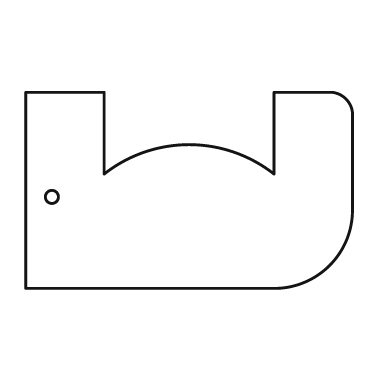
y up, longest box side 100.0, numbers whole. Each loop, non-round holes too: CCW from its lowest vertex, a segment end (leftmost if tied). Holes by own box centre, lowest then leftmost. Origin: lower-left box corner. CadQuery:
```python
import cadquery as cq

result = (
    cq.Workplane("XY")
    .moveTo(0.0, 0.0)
    .lineTo(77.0, 0.0)
    .threePointArc((93.0, 7.0), (100.0, 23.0))
    .lineTo(100.0, 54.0)
    .threePointArc((98.0, 58.0), (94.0, 60.0))
    .lineTo(76.0, 60.0)
    .lineTo(76.0, 35.0)
    .threePointArc((50.0, 44.0), (24.0, 35.0))
    .lineTo(24.0, 60.0)
    .lineTo(0.0, 60.0)
    .close()
    .moveTo(8.0, 28.0)
    .circle(2.0)
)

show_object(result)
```